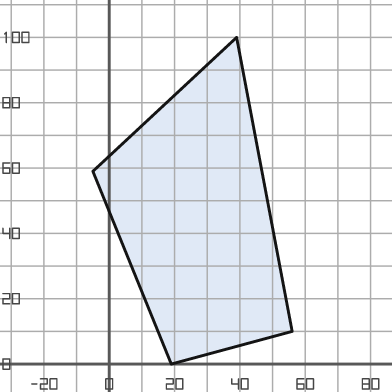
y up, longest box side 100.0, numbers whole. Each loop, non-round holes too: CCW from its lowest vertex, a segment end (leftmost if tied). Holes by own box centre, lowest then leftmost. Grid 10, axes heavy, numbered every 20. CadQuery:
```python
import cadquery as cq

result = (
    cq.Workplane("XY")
    .moveTo(19.0, 0.0)
    .lineTo(56.0, 10.0)
    .lineTo(39.0, 100.0)
    .lineTo(-5.0, 59.0)
    .close()
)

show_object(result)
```